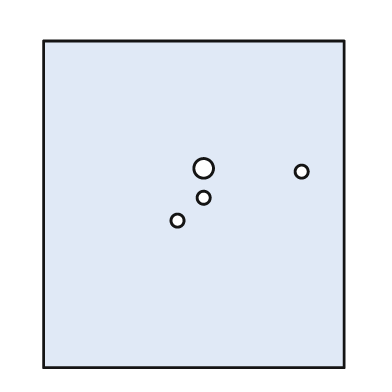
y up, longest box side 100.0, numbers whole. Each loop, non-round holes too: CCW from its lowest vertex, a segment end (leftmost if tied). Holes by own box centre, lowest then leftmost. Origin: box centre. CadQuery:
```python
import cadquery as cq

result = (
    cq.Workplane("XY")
    .moveTo(-46.0, -50.0)
    .lineTo(46.0, -50.0)
    .lineTo(46.0, 50.0)
    .lineTo(-46.0, 50.0)
    .close()
    .moveTo(-5.0, -5.0)
    .circle(2.0)
    .moveTo(3.0, 2.0)
    .circle(2.0)
    .moveTo(33.0, 10.0)
    .circle(2.0)
    .moveTo(3.0, 11.0)
    .circle(3.0)
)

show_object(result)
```